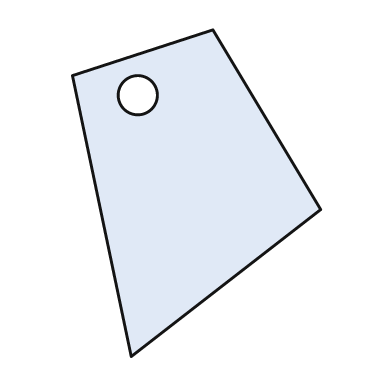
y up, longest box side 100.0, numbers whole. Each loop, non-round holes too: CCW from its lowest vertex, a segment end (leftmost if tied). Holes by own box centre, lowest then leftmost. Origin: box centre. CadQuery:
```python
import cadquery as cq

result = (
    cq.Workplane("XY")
    .moveTo(-20.0, -50.0)
    .lineTo(38.0, -5.0)
    .lineTo(5.0, 50.0)
    .lineTo(-38.0, 36.0)
    .close()
    .moveTo(-18.0, 30.0)
    .circle(6.0)
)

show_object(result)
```